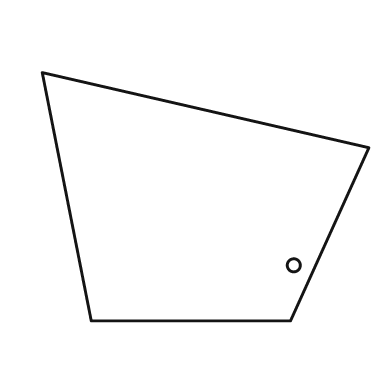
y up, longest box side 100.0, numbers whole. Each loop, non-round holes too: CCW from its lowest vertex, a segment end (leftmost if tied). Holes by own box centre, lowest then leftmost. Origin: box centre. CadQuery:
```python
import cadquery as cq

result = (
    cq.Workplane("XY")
    .moveTo(-35.0, -38.0)
    .lineTo(26.0, -38.0)
    .lineTo(50.0, 15.0)
    .lineTo(-50.0, 38.0)
    .close()
    .moveTo(27.0, -21.0)
    .circle(2.0)
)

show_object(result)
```